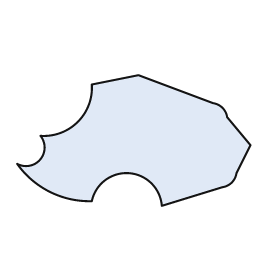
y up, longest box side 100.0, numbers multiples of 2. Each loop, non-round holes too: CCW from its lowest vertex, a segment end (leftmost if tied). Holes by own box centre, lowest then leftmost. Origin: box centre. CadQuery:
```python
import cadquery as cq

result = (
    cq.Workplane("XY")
    .moveTo(12.0, -28.0)
    .lineTo(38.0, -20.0)
    .threePointArc((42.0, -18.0), (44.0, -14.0))
    .lineTo(50.0, -2.0)
    .lineTo(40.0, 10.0)
    .threePointArc((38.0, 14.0), (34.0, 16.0))
    .lineTo(2.0, 28.0)
    .lineTo(-18.0, 24.0)
    .threePointArc((-24.0, 8.0), (-40.0, 2.0))
    .threePointArc((-40.0, -8.0), (-50.0, -10.0))
    .threePointArc((-36.0, -22.0), (-18.0, -26.0))
    .threePointArc((-2.0, -14.0), (12.0, -28.0))
    .close()
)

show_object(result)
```